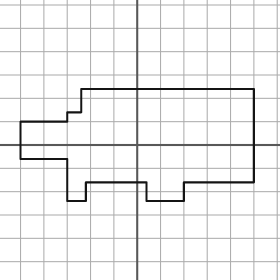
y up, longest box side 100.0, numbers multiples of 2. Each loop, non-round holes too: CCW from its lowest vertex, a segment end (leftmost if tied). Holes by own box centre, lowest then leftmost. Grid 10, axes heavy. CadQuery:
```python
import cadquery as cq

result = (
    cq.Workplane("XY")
    .moveTo(-30.0, -24.0)
    .lineTo(-22.0, -24.0)
    .lineTo(-22.0, -16.0)
    .lineTo(4.0, -16.0)
    .lineTo(4.0, -24.0)
    .lineTo(20.0, -24.0)
    .lineTo(20.0, -16.0)
    .lineTo(50.0, -16.0)
    .lineTo(50.0, 24.0)
    .lineTo(-24.0, 24.0)
    .lineTo(-24.0, 14.0)
    .lineTo(-30.0, 14.0)
    .lineTo(-30.0, 10.0)
    .lineTo(-50.0, 10.0)
    .lineTo(-50.0, -6.0)
    .lineTo(-30.0, -6.0)
    .close()
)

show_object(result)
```